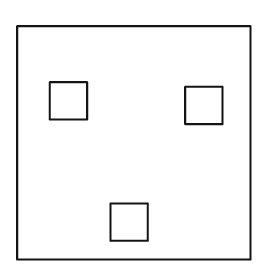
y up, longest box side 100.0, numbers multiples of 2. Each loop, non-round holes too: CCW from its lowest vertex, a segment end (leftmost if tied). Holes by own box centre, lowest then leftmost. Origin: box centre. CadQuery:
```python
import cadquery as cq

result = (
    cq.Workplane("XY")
    .moveTo(-50.0, -50.0)
    .lineTo(50.0, -50.0)
    .lineTo(50.0, 50.0)
    .lineTo(-50.0, 50.0)
    .close()
    .moveTo(-10.0, -42.0)
    .lineTo(6.0, -42.0)
    .lineTo(6.0, -26.0)
    .lineTo(-10.0, -26.0)
    .close()
    .moveTo(22.0, 8.0)
    .lineTo(38.0, 8.0)
    .lineTo(38.0, 24.0)
    .lineTo(22.0, 24.0)
    .close()
    .moveTo(-36.0, 10.0)
    .lineTo(-20.0, 10.0)
    .lineTo(-20.0, 26.0)
    .lineTo(-36.0, 26.0)
    .close()
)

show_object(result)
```